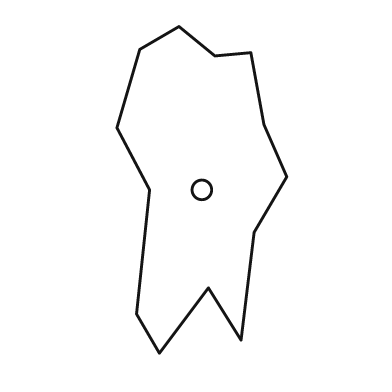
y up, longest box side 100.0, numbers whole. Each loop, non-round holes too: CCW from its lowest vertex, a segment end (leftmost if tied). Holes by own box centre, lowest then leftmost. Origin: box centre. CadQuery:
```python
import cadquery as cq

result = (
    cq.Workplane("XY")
    .moveTo(-13.0, -50.0)
    .lineTo(2.0, -30.0)
    .lineTo(12.0, -46.0)
    .lineTo(16.0, -13.0)
    .lineTo(26.0, 4.0)
    .lineTo(19.0, 20.0)
    .lineTo(15.0, 42.0)
    .lineTo(4.0, 41.0)
    .lineTo(-7.0, 50.0)
    .lineTo(-19.0, 43.0)
    .lineTo(-26.0, 19.0)
    .lineTo(-16.0, 0.0)
    .lineTo(-20.0, -38.0)
    .close()
    .moveTo(0.0, 0.0)
    .circle(3.0)
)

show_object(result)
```